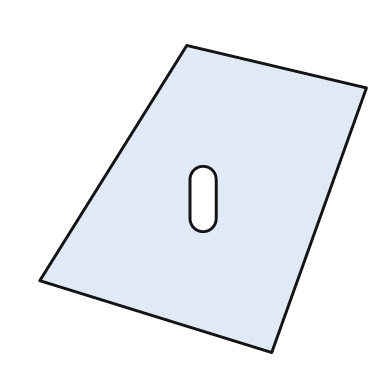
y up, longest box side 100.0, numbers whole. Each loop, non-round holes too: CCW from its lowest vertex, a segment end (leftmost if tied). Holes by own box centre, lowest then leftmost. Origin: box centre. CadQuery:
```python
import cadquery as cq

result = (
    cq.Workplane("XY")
    .moveTo(21.0, -47.0)
    .lineTo(50.0, 34.0)
    .lineTo(-5.0, 47.0)
    .lineTo(-50.0, -25.0)
    .close()
    .moveTo(-4.0, -6.0)
    .threePointArc((0.0, -10.0), (4.0, -6.0))
    .lineTo(4.0, 6.0)
    .threePointArc((0.0, 10.0), (-4.0, 6.0))
    .close()
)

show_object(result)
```